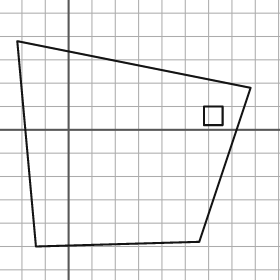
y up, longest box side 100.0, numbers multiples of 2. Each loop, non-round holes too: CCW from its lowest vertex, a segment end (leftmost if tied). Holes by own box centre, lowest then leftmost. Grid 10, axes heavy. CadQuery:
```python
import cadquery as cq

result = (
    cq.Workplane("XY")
    .moveTo(-14.0, -50.0)
    .lineTo(56.0, -48.0)
    .lineTo(78.0, 18.0)
    .lineTo(-22.0, 38.0)
    .close()
    .moveTo(58.0, 2.0)
    .lineTo(66.0, 2.0)
    .lineTo(66.0, 10.0)
    .lineTo(58.0, 10.0)
    .close()
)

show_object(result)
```